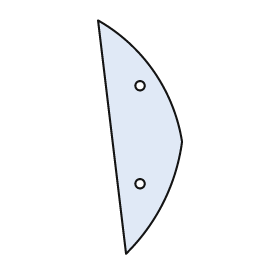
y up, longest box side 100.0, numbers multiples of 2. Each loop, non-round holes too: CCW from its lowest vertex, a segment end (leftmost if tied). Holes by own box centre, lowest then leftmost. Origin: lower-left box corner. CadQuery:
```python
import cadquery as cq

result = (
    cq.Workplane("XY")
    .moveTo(12.0, 0.0)
    .threePointArc((28.0, 22.0), (36.0, 48.0))
    .threePointArc((24.0, 78.0), (0.0, 100.0))
    .close()
    .moveTo(18.0, 30.0)
    .circle(2.0)
    .moveTo(18.0, 72.0)
    .circle(2.0)
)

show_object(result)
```